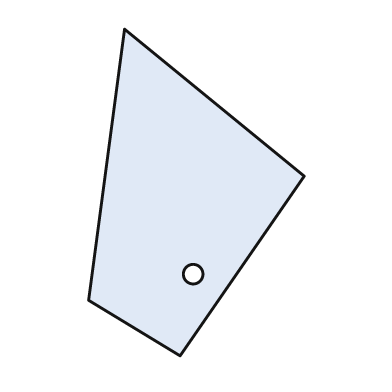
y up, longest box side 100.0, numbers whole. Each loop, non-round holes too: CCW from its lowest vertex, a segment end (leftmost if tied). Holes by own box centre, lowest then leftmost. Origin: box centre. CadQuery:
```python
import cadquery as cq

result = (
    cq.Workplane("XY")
    .moveTo(-5.0, -50.0)
    .lineTo(33.0, 5.0)
    .lineTo(-22.0, 50.0)
    .lineTo(-33.0, -33.0)
    .close()
    .moveTo(-1.0, -25.0)
    .circle(3.0)
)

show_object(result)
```